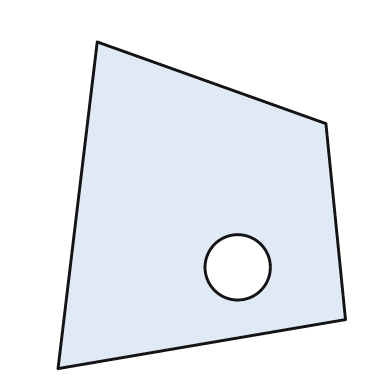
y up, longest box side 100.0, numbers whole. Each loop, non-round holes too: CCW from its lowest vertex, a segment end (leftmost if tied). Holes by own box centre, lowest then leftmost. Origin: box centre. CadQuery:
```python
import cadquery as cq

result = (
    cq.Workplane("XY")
    .moveTo(-44.0, -50.0)
    .lineTo(44.0, -35.0)
    .lineTo(38.0, 25.0)
    .lineTo(-32.0, 50.0)
    .close()
    .moveTo(11.0, -19.0)
    .circle(10.0)
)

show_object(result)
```